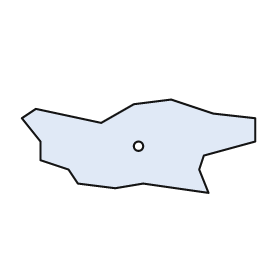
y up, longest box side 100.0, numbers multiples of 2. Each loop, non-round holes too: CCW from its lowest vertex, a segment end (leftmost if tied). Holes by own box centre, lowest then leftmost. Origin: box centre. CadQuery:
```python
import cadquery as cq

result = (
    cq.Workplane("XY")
    .moveTo(30.0, -20.0)
    .lineTo(26.0, -10.0)
    .lineTo(28.0, -4.0)
    .lineTo(50.0, 2.0)
    .lineTo(50.0, 12.0)
    .lineTo(32.0, 14.0)
    .lineTo(14.0, 20.0)
    .lineTo(-2.0, 18.0)
    .lineTo(-16.0, 10.0)
    .lineTo(-44.0, 16.0)
    .lineTo(-50.0, 12.0)
    .lineTo(-42.0, 2.0)
    .lineTo(-42.0, -6.0)
    .lineTo(-30.0, -10.0)
    .lineTo(-26.0, -16.0)
    .lineTo(-10.0, -18.0)
    .lineTo(2.0, -16.0)
    .close()
    .moveTo(0.0, 0.0)
    .circle(2.0)
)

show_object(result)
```